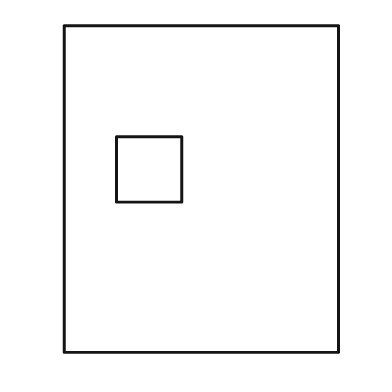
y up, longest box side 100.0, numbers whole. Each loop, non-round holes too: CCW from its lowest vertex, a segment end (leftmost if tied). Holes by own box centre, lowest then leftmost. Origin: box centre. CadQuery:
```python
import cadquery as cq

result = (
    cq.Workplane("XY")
    .moveTo(-42.0, -50.0)
    .lineTo(42.0, -50.0)
    .lineTo(42.0, 50.0)
    .lineTo(-42.0, 50.0)
    .close()
    .moveTo(-26.0, -4.0)
    .lineTo(-6.0, -4.0)
    .lineTo(-6.0, 16.0)
    .lineTo(-26.0, 16.0)
    .close()
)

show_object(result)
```